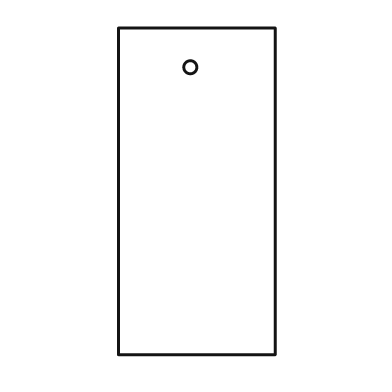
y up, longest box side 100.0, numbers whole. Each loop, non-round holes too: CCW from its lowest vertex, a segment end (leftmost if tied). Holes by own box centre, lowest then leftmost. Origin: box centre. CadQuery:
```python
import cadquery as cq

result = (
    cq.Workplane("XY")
    .moveTo(-24.0, -50.0)
    .lineTo(24.0, -50.0)
    .lineTo(24.0, 50.0)
    .lineTo(-24.0, 50.0)
    .close()
    .moveTo(-2.0, 38.0)
    .circle(2.0)
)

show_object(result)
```